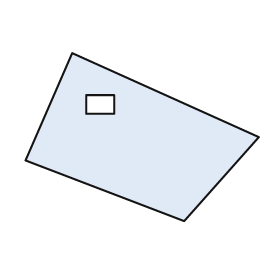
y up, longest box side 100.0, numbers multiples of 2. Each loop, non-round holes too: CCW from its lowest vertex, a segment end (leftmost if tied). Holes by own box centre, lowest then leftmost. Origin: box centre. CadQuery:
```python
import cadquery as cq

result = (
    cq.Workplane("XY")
    .moveTo(18.0, -36.0)
    .lineTo(50.0, 0.0)
    .lineTo(-30.0, 36.0)
    .lineTo(-50.0, -10.0)
    .close()
    .moveTo(-24.0, 10.0)
    .lineTo(-12.0, 10.0)
    .lineTo(-12.0, 18.0)
    .lineTo(-24.0, 18.0)
    .close()
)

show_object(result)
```